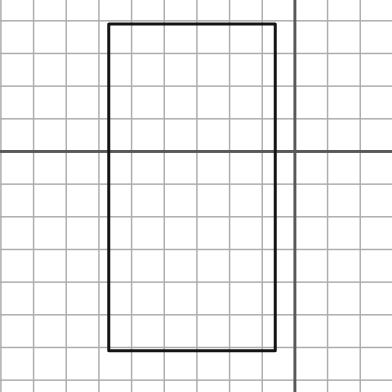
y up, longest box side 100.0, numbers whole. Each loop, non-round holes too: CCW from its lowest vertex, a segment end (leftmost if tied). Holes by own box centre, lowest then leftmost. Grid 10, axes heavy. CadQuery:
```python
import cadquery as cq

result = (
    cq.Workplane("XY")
    .moveTo(-57.0, -61.0)
    .lineTo(-6.0, -61.0)
    .lineTo(-6.0, 39.0)
    .lineTo(-57.0, 39.0)
    .close()
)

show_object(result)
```